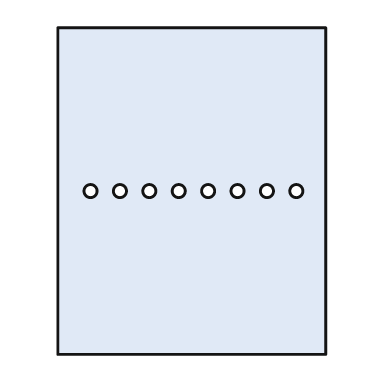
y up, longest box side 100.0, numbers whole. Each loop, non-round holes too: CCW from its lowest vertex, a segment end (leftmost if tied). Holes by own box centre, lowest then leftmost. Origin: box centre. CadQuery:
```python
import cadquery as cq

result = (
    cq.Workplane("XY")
    .moveTo(-41.0, -50.0)
    .lineTo(41.0, -50.0)
    .lineTo(41.0, 50.0)
    .lineTo(-41.0, 50.0)
    .close()
    .moveTo(-31.0, 0.0)
    .circle(2.0)
    .moveTo(-22.0, 0.0)
    .circle(2.0)
    .moveTo(-13.0, 0.0)
    .circle(2.0)
    .moveTo(-4.0, 0.0)
    .circle(2.0)
    .moveTo(5.0, 0.0)
    .circle(2.0)
    .moveTo(14.0, 0.0)
    .circle(2.0)
    .moveTo(23.0, 0.0)
    .circle(2.0)
    .moveTo(32.0, 0.0)
    .circle(2.0)
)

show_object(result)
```